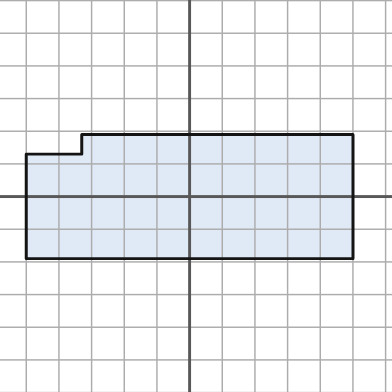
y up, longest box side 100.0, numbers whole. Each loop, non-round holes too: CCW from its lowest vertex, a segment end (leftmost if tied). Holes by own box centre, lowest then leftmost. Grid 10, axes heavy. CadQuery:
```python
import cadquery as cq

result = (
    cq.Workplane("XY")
    .moveTo(-50.0, -19.0)
    .lineTo(50.0, -19.0)
    .lineTo(50.0, 19.0)
    .lineTo(-33.0, 19.0)
    .lineTo(-33.0, 13.0)
    .lineTo(-50.0, 13.0)
    .close()
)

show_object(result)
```